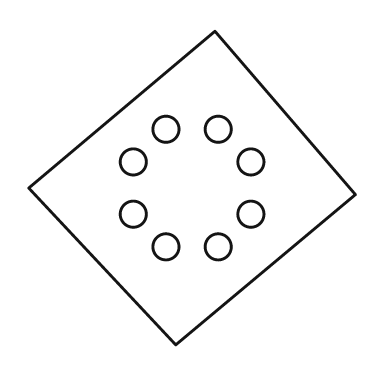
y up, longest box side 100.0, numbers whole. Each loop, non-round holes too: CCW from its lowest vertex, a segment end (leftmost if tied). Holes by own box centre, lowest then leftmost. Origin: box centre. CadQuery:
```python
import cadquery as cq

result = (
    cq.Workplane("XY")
    .moveTo(-5.0, -48.0)
    .lineTo(50.0, -2.0)
    .lineTo(7.0, 48.0)
    .lineTo(-50.0, 0.0)
    .close()
    .moveTo(-8.0, -18.0)
    .circle(4.0)
    .moveTo(8.0, -18.0)
    .circle(4.0)
    .moveTo(-18.0, -8.0)
    .circle(4.0)
    .moveTo(18.0, -8.0)
    .circle(4.0)
    .moveTo(-18.0, 8.0)
    .circle(4.0)
    .moveTo(18.0, 8.0)
    .circle(4.0)
    .moveTo(-8.0, 18.0)
    .circle(4.0)
    .moveTo(8.0, 18.0)
    .circle(4.0)
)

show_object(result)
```